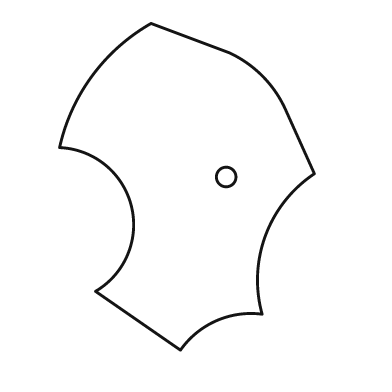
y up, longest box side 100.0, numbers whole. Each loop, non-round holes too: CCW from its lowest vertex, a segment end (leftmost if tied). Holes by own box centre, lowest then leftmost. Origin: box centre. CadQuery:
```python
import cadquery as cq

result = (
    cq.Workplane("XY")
    .moveTo(-2.0, -50.0)
    .threePointArc((9.0, -41.0), (23.0, -39.0))
    .threePointArc((24.0, -15.0), (39.0, 4.0))
    .lineTo(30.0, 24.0)
    .threePointArc((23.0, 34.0), (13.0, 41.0))
    .lineTo(-11.0, 50.0)
    .threePointArc((-29.0, 34.0), (-39.0, 12.0))
    .threePointArc((-17.0, -6.0), (-28.0, -32.0))
    .close()
    .moveTo(12.0, 3.0)
    .circle(3.0)
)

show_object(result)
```